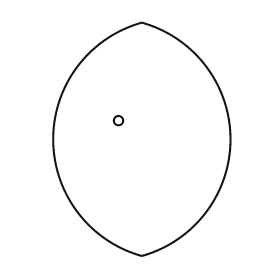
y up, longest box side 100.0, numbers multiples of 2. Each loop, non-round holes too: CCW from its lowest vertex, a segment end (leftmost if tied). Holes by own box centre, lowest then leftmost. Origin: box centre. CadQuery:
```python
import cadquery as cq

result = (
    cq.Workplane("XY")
    .moveTo(0.0, -50.0)
    .threePointArc((38.0, 0.0), (0.0, 50.0))
    .threePointArc((-38.0, 0.0), (0.0, -50.0))
    .close()
    .moveTo(-10.0, 8.0)
    .circle(2.0)
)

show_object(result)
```